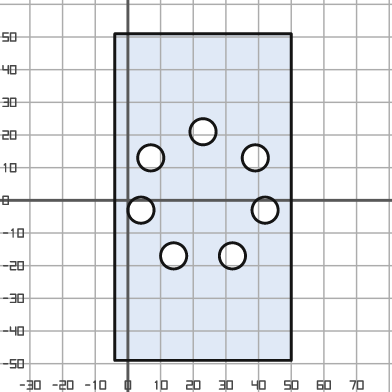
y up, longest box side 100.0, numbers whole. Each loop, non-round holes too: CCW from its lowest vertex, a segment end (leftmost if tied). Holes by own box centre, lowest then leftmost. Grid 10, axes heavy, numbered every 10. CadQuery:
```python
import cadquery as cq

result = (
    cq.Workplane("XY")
    .moveTo(-4.0, -49.0)
    .lineTo(50.0, -49.0)
    .lineTo(50.0, 51.0)
    .lineTo(-4.0, 51.0)
    .close()
    .moveTo(14.0, -17.0)
    .circle(4.0)
    .moveTo(32.0, -17.0)
    .circle(4.0)
    .moveTo(4.0, -3.0)
    .circle(4.0)
    .moveTo(42.0, -3.0)
    .circle(4.0)
    .moveTo(7.0, 13.0)
    .circle(4.0)
    .moveTo(39.0, 13.0)
    .circle(4.0)
    .moveTo(23.0, 21.0)
    .circle(4.0)
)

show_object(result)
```